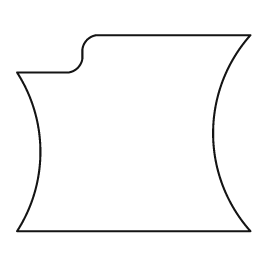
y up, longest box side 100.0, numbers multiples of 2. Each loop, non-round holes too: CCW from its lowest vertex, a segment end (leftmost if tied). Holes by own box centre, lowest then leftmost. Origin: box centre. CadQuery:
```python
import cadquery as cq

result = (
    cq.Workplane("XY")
    .moveTo(-50.0, -42.0)
    .lineTo(50.0, -42.0)
    .threePointArc((34.0, 0.0), (50.0, 42.0))
    .lineTo(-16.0, 42.0)
    .threePointArc((-20.0, 40.0), (-22.0, 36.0))
    .lineTo(-22.0, 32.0)
    .threePointArc((-24.0, 28.0), (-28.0, 26.0))
    .lineTo(-50.0, 26.0)
    .threePointArc((-40.0, -8.0), (-50.0, -42.0))
    .close()
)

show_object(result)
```